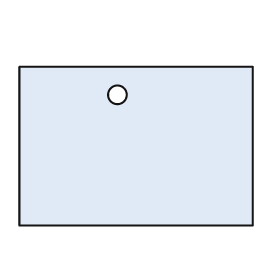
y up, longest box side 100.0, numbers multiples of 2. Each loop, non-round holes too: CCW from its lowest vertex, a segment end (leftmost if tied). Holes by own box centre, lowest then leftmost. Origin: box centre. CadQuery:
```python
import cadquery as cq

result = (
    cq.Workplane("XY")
    .moveTo(-50.0, -34.0)
    .lineTo(50.0, -34.0)
    .lineTo(50.0, 34.0)
    .lineTo(-50.0, 34.0)
    .close()
    .moveTo(-8.0, 22.0)
    .circle(4.0)
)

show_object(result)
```